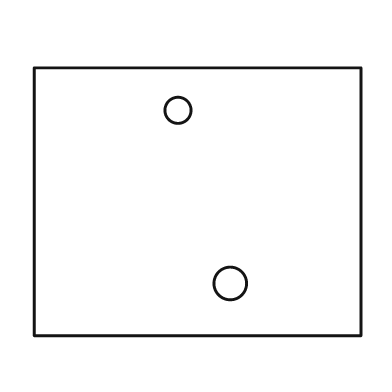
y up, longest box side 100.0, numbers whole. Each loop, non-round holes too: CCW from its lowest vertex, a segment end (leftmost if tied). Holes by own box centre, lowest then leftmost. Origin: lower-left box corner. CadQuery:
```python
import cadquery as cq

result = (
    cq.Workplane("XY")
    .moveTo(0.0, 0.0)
    .lineTo(100.0, 0.0)
    .lineTo(100.0, 82.0)
    .lineTo(0.0, 82.0)
    .close()
    .moveTo(60.0, 16.0)
    .circle(5.0)
    .moveTo(44.0, 69.0)
    .circle(4.0)
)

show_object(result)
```